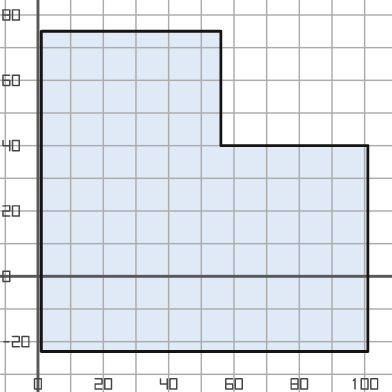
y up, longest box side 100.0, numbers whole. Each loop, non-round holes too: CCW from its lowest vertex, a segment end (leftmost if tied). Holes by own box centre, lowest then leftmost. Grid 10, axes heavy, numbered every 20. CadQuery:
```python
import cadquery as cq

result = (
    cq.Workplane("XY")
    .moveTo(1.0, -23.0)
    .lineTo(101.0, -23.0)
    .lineTo(101.0, 40.0)
    .lineTo(56.0, 40.0)
    .lineTo(56.0, 75.0)
    .lineTo(1.0, 75.0)
    .close()
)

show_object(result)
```